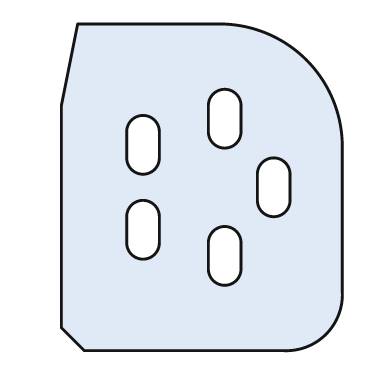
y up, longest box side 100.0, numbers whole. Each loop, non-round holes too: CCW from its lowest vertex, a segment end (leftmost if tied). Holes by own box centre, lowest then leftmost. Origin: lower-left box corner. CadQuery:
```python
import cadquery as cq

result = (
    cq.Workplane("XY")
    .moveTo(7.0, 0.0)
    .lineTo(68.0, 0.0)
    .threePointArc((81.0, 5.0), (86.0, 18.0))
    .lineTo(86.0, 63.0)
    .threePointArc((75.0, 89.0), (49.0, 100.0))
    .lineTo(5.0, 100.0)
    .lineTo(0.0, 75.0)
    .lineTo(0.0, 7.0)
    .close()
    .moveTo(45.0, 25.0)
    .threePointArc((50.0, 20.0), (55.0, 25.0))
    .lineTo(55.0, 33.0)
    .threePointArc((50.0, 38.0), (45.0, 33.0))
    .close()
    .moveTo(20.0, 33.0)
    .threePointArc((25.0, 28.0), (30.0, 33.0))
    .lineTo(30.0, 41.0)
    .threePointArc((25.0, 46.0), (20.0, 41.0))
    .close()
    .moveTo(60.0, 46.0)
    .threePointArc((65.0, 41.0), (70.0, 46.0))
    .lineTo(70.0, 54.0)
    .threePointArc((65.0, 59.0), (60.0, 54.0))
    .close()
    .moveTo(20.0, 59.0)
    .threePointArc((25.0, 54.0), (30.0, 59.0))
    .lineTo(30.0, 67.0)
    .threePointArc((25.0, 72.0), (20.0, 67.0))
    .close()
    .moveTo(45.0, 67.0)
    .threePointArc((50.0, 62.0), (55.0, 67.0))
    .lineTo(55.0, 75.0)
    .threePointArc((50.0, 80.0), (45.0, 75.0))
    .close()
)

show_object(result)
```